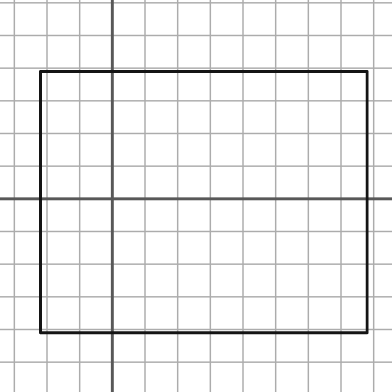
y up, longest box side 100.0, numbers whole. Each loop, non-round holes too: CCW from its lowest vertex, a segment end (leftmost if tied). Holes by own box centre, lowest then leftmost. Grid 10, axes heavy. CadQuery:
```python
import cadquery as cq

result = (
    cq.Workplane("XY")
    .moveTo(-22.0, -41.0)
    .lineTo(78.0, -41.0)
    .lineTo(78.0, 39.0)
    .lineTo(-22.0, 39.0)
    .close()
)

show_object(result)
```